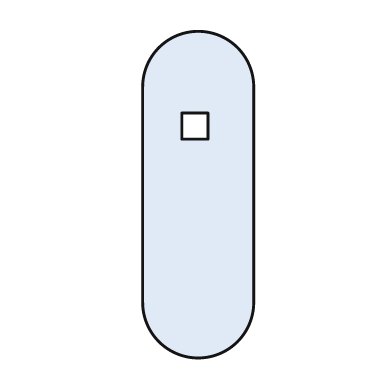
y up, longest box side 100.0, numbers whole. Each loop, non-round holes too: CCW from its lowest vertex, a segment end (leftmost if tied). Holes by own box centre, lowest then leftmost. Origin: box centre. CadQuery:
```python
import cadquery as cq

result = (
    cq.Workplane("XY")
    .moveTo(-17.0, -33.0)
    .threePointArc((0.0, -50.0), (17.0, -33.0))
    .lineTo(17.0, 33.0)
    .threePointArc((0.0, 50.0), (-17.0, 33.0))
    .close()
    .moveTo(-5.0, 17.0)
    .lineTo(3.0, 17.0)
    .lineTo(3.0, 25.0)
    .lineTo(-5.0, 25.0)
    .close()
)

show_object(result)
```